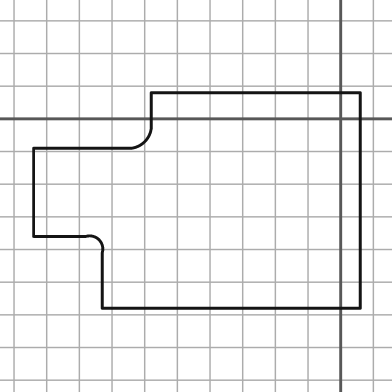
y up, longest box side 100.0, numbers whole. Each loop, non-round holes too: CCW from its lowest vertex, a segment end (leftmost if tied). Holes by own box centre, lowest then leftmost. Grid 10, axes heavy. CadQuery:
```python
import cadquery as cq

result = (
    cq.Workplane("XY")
    .moveTo(-73.0, -58.0)
    .lineTo(6.0, -58.0)
    .lineTo(6.0, 8.0)
    .lineTo(-58.0, 8.0)
    .lineTo(-58.0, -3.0)
    .threePointArc((-60.0, -7.0), (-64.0, -9.0))
    .lineTo(-94.0, -9.0)
    .lineTo(-94.0, -36.0)
    .lineTo(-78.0, -36.0)
    .threePointArc((-74.0, -37.0), (-73.0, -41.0))
    .close()
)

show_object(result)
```